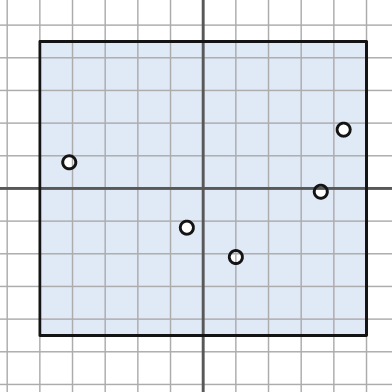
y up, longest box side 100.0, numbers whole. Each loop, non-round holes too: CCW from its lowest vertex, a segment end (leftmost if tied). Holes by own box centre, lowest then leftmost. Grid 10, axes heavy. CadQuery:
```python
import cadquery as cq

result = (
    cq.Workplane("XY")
    .moveTo(-50.0, -45.0)
    .lineTo(50.0, -45.0)
    .lineTo(50.0, 45.0)
    .lineTo(-50.0, 45.0)
    .close()
    .moveTo(10.0, -21.0)
    .circle(2.0)
    .moveTo(-5.0, -12.0)
    .circle(2.0)
    .moveTo(36.0, -1.0)
    .circle(2.0)
    .moveTo(-41.0, 8.0)
    .circle(2.0)
    .moveTo(43.0, 18.0)
    .circle(2.0)
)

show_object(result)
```